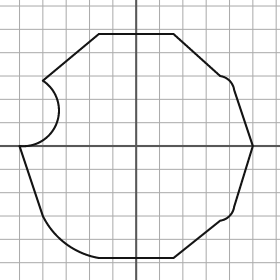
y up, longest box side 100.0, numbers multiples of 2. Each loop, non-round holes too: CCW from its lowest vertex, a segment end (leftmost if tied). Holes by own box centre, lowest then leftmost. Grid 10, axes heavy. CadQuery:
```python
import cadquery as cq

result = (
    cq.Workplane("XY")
    .moveTo(-16.0, -48.0)
    .lineTo(16.0, -48.0)
    .lineTo(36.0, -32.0)
    .threePointArc((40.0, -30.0), (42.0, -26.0))
    .lineTo(50.0, 0.0)
    .lineTo(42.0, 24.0)
    .threePointArc((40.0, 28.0), (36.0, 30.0))
    .lineTo(16.0, 48.0)
    .lineTo(-16.0, 48.0)
    .lineTo(-40.0, 28.0)
    .threePointArc((-34.0, 10.0), (-50.0, 0.0))
    .lineTo(-40.0, -30.0)
    .threePointArc((-30.0, -42.0), (-16.0, -48.0))
    .close()
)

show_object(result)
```